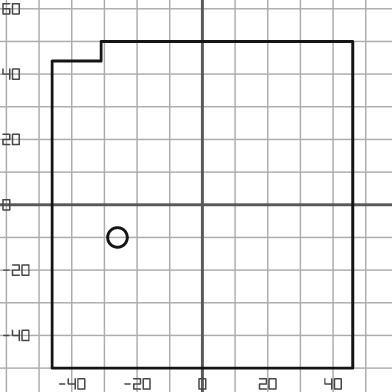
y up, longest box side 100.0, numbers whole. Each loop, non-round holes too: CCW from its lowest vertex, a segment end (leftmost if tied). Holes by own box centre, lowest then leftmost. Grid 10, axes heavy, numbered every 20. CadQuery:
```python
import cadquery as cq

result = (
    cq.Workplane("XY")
    .moveTo(-46.0, -50.0)
    .lineTo(46.0, -50.0)
    .lineTo(46.0, 50.0)
    .lineTo(-31.0, 50.0)
    .lineTo(-31.0, 44.0)
    .lineTo(-46.0, 44.0)
    .close()
    .moveTo(-26.0, -10.0)
    .circle(3.0)
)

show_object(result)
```